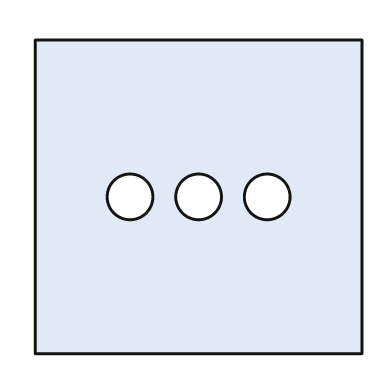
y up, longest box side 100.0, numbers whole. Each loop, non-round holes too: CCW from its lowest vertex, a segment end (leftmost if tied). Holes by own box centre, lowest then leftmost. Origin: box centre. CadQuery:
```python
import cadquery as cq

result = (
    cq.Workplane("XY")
    .moveTo(-50.0, -48.0)
    .lineTo(50.0, -48.0)
    .lineTo(50.0, 48.0)
    .lineTo(-50.0, 48.0)
    .close()
    .moveTo(-21.0, 0.0)
    .circle(7.0)
    .moveTo(0.0, 0.0)
    .circle(7.0)
    .moveTo(21.0, 0.0)
    .circle(7.0)
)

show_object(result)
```